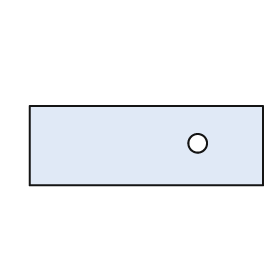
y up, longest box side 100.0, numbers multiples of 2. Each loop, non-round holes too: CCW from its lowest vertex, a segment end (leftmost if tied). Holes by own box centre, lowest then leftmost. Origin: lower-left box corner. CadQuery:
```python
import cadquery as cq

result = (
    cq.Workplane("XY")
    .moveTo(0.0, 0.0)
    .lineTo(100.0, 0.0)
    .lineTo(100.0, 34.0)
    .lineTo(0.0, 34.0)
    .close()
    .moveTo(72.0, 18.0)
    .circle(4.0)
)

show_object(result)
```